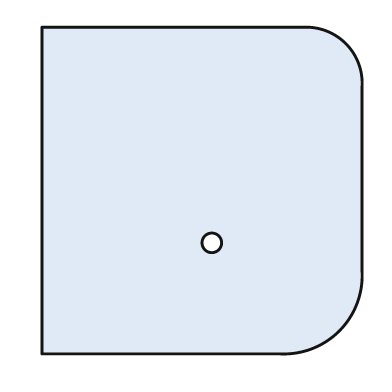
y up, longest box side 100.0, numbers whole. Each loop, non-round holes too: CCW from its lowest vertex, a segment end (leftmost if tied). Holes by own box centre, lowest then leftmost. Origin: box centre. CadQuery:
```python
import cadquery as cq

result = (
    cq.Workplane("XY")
    .moveTo(-49.0, -50.0)
    .lineTo(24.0, -50.0)
    .threePointArc((42.0, -43.0), (49.0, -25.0))
    .lineTo(49.0, 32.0)
    .threePointArc((44.0, 45.0), (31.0, 50.0))
    .lineTo(-49.0, 50.0)
    .close()
    .moveTo(3.0, -16.0)
    .circle(3.0)
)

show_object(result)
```